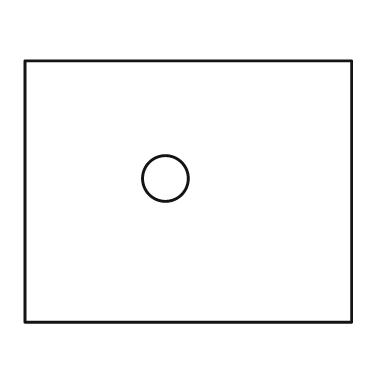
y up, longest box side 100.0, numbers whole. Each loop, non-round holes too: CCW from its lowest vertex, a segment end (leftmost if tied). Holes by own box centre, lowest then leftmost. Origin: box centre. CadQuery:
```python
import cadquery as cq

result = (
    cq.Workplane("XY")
    .moveTo(-50.0, -40.0)
    .lineTo(50.0, -40.0)
    .lineTo(50.0, 40.0)
    .lineTo(-50.0, 40.0)
    .close()
    .moveTo(-7.0, 4.0)
    .circle(7.0)
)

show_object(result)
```